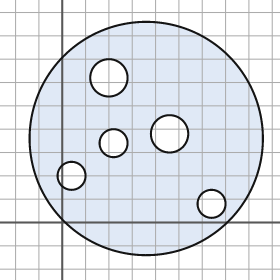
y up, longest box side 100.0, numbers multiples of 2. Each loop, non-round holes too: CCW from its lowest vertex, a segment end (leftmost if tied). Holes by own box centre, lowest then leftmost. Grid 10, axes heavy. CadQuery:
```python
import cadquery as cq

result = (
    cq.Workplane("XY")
    .moveTo(36.0, 36.0)
    .circle(50.0)
    .moveTo(64.0, 8.0)
    .circle(6.0)
    .moveTo(4.0, 20.0)
    .circle(6.0)
    .moveTo(22.0, 34.0)
    .circle(6.0)
    .moveTo(46.0, 38.0)
    .circle(8.0)
    .moveTo(20.0, 62.0)
    .circle(8.0)
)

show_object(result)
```